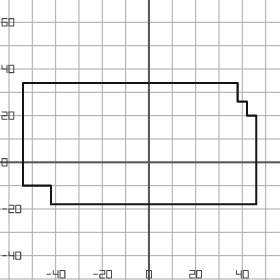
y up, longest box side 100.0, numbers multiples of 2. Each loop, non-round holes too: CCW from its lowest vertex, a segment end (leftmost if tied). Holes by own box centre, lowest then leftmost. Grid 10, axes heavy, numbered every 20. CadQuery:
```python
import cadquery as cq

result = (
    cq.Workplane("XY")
    .moveTo(-42.0, -18.0)
    .lineTo(46.0, -18.0)
    .lineTo(46.0, 20.0)
    .lineTo(42.0, 20.0)
    .lineTo(42.0, 26.0)
    .lineTo(38.0, 26.0)
    .lineTo(38.0, 34.0)
    .lineTo(-54.0, 34.0)
    .lineTo(-54.0, -10.0)
    .lineTo(-42.0, -10.0)
    .close()
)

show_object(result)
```